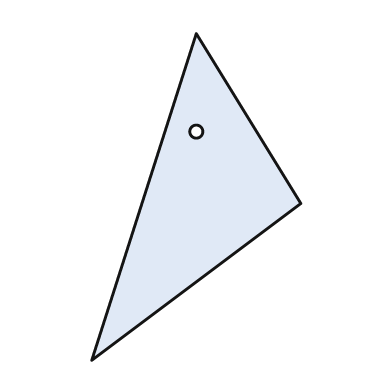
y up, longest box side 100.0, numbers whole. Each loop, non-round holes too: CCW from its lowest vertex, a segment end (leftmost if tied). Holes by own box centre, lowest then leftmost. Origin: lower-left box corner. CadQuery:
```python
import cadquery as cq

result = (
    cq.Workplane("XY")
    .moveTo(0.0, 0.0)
    .lineTo(64.0, 48.0)
    .lineTo(32.0, 100.0)
    .close()
    .moveTo(32.0, 70.0)
    .circle(2.0)
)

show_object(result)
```